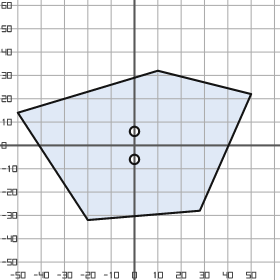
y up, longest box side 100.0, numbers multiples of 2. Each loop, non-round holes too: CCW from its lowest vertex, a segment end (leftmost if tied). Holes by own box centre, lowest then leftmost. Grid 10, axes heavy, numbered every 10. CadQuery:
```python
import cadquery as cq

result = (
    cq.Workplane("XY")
    .moveTo(-20.0, -32.0)
    .lineTo(28.0, -28.0)
    .lineTo(50.0, 22.0)
    .lineTo(10.0, 32.0)
    .lineTo(-50.0, 14.0)
    .close()
    .moveTo(0.0, -6.0)
    .circle(2.0)
    .moveTo(0.0, 6.0)
    .circle(2.0)
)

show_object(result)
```